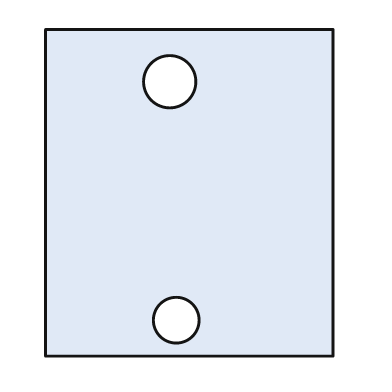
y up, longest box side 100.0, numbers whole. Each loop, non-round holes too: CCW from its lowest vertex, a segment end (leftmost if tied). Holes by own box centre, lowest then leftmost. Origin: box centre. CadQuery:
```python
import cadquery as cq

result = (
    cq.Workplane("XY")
    .moveTo(-44.0, -50.0)
    .lineTo(44.0, -50.0)
    .lineTo(44.0, 50.0)
    .lineTo(-44.0, 50.0)
    .close()
    .moveTo(-4.0, -39.0)
    .circle(7.0)
    .moveTo(-6.0, 34.0)
    .circle(8.0)
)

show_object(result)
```